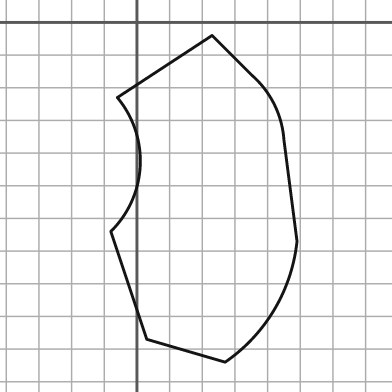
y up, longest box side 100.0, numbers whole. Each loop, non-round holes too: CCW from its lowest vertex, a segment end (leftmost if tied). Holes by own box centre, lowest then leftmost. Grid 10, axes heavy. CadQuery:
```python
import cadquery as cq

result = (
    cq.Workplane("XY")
    .moveTo(27.0, -104.0)
    .threePointArc((42.0, -88.0), (49.0, -67.0))
    .lineTo(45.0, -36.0)
    .threePointArc((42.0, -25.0), (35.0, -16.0))
    .lineTo(23.0, -4.0)
    .lineTo(-6.0, -23.0)
    .threePointArc((1.0, -44.0), (-8.0, -64.0))
    .lineTo(3.0, -97.0)
    .close()
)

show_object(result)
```